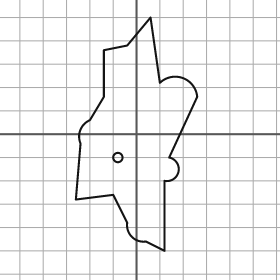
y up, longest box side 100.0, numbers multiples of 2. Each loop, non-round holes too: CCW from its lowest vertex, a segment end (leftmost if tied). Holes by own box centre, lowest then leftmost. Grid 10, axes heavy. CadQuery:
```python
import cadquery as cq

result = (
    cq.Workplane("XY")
    .moveTo(12.0, -50.0)
    .lineTo(12.0, -20.0)
    .threePointArc((18.0, -16.0), (14.0, -10.0))
    .lineTo(26.0, 16.0)
    .threePointArc((20.0, 24.0), (10.0, 22.0))
    .lineTo(6.0, 50.0)
    .lineTo(-4.0, 38.0)
    .lineTo(-14.0, 36.0)
    .lineTo(-14.0, 16.0)
    .lineTo(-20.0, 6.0)
    .threePointArc((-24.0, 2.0), (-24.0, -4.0))
    .lineTo(-26.0, -28.0)
    .lineTo(-10.0, -26.0)
    .lineTo(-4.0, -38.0)
    .threePointArc((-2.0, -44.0), (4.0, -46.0))
    .close()
    .moveTo(-8.0, -10.0)
    .circle(2.0)
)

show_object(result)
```